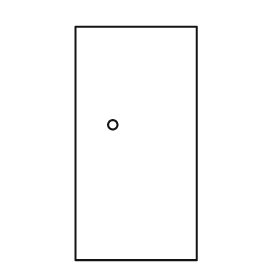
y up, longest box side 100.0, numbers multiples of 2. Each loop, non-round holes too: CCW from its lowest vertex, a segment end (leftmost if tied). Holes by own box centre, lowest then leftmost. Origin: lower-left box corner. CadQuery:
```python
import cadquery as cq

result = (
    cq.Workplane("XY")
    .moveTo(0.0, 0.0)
    .lineTo(52.0, 0.0)
    .lineTo(52.0, 100.0)
    .lineTo(0.0, 100.0)
    .close()
    .moveTo(16.0, 58.0)
    .circle(2.0)
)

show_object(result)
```